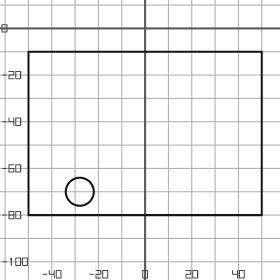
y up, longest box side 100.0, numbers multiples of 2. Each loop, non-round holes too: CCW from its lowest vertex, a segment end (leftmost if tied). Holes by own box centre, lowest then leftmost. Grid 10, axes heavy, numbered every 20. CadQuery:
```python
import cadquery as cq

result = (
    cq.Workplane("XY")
    .moveTo(-50.0, -80.0)
    .lineTo(50.0, -80.0)
    .lineTo(50.0, -10.0)
    .lineTo(-50.0, -10.0)
    .close()
    .moveTo(-28.0, -70.0)
    .circle(6.0)
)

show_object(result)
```